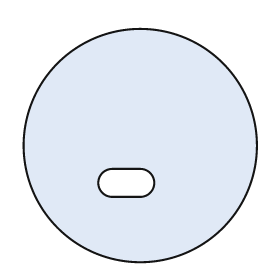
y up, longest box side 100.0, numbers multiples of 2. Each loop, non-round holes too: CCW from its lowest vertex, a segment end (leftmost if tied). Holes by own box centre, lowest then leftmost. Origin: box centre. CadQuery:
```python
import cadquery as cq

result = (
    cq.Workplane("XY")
    .moveTo(0.0, 0.0)
    .circle(50.0)
    .moveTo(-12.0, -22.0)
    .lineTo(0.0, -22.0)
    .threePointArc((6.0, -16.0), (0.0, -10.0))
    .lineTo(-12.0, -10.0)
    .threePointArc((-18.0, -16.0), (-12.0, -22.0))
    .close()
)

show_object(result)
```